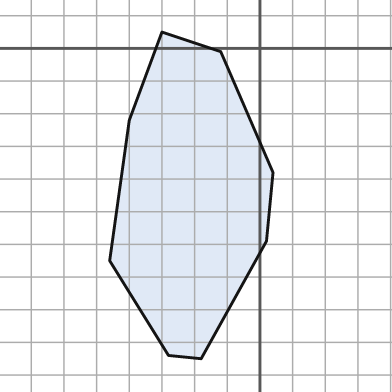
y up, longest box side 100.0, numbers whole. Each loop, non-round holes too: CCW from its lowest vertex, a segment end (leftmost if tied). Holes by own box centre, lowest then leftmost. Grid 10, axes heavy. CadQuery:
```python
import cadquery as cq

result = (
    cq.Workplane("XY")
    .moveTo(-18.0, -95.0)
    .lineTo(2.0, -59.0)
    .lineTo(4.0, -38.0)
    .lineTo(-12.0, -1.0)
    .lineTo(-30.0, 5.0)
    .lineTo(-40.0, -22.0)
    .lineTo(-46.0, -65.0)
    .lineTo(-28.0, -94.0)
    .close()
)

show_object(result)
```